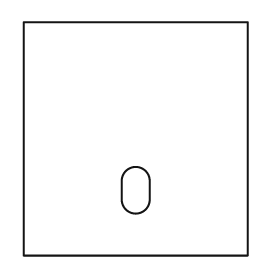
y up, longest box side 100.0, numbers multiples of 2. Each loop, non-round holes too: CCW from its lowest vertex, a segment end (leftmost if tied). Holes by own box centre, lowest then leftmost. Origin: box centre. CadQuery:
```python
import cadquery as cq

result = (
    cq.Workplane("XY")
    .moveTo(-48.0, -50.0)
    .lineTo(48.0, -50.0)
    .lineTo(48.0, 50.0)
    .lineTo(-48.0, 50.0)
    .close()
    .moveTo(-6.0, -26.0)
    .threePointArc((0.0, -32.0), (6.0, -26.0))
    .lineTo(6.0, -18.0)
    .threePointArc((0.0, -12.0), (-6.0, -18.0))
    .close()
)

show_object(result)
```